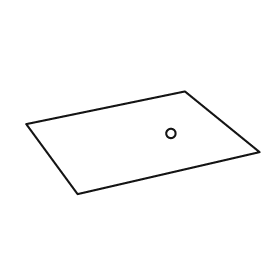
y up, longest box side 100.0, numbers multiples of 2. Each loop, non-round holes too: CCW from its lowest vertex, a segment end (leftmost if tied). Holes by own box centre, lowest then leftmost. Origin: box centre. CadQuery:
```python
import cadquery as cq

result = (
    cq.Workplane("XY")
    .moveTo(-28.0, -22.0)
    .lineTo(50.0, -4.0)
    .lineTo(18.0, 22.0)
    .lineTo(-50.0, 8.0)
    .close()
    .moveTo(12.0, 4.0)
    .circle(2.0)
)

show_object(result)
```